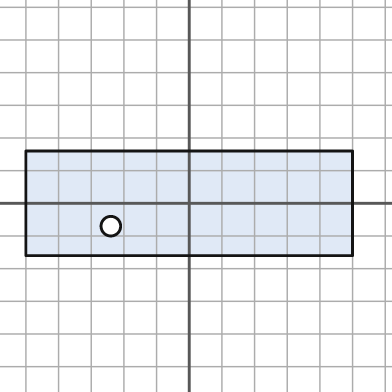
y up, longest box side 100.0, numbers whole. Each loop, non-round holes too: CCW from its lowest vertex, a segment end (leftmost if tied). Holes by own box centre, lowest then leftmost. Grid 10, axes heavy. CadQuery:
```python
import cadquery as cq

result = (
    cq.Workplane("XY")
    .moveTo(-50.0, -16.0)
    .lineTo(50.0, -16.0)
    .lineTo(50.0, 16.0)
    .lineTo(-50.0, 16.0)
    .close()
    .moveTo(-24.0, -7.0)
    .circle(3.0)
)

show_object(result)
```